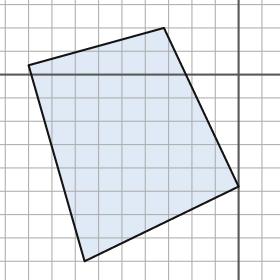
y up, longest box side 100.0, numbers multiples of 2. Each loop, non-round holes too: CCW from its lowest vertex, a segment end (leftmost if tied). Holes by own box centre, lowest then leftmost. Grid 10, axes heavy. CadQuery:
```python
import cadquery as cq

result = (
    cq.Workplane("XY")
    .moveTo(-66.0, -80.0)
    .lineTo(0.0, -48.0)
    .lineTo(-32.0, 20.0)
    .lineTo(-90.0, 4.0)
    .close()
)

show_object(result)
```